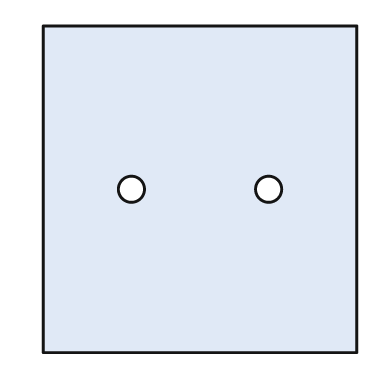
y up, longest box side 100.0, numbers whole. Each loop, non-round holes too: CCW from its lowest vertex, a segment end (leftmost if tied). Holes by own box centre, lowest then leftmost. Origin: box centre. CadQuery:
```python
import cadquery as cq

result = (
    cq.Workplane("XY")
    .moveTo(-48.0, -50.0)
    .lineTo(48.0, -50.0)
    .lineTo(48.0, 50.0)
    .lineTo(-48.0, 50.0)
    .close()
    .moveTo(-21.0, 0.0)
    .circle(4.0)
    .moveTo(21.0, 0.0)
    .circle(4.0)
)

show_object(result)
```